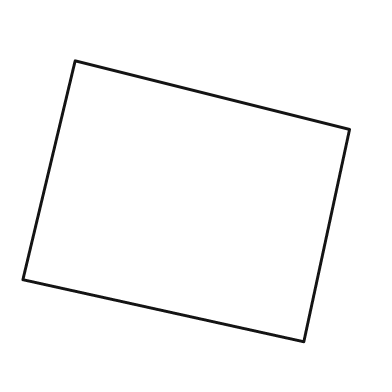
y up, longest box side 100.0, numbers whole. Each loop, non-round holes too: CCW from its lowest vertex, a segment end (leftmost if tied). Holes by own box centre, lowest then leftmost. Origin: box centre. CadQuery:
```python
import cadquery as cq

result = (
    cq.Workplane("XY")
    .moveTo(36.0, -43.0)
    .lineTo(50.0, 22.0)
    .lineTo(-34.0, 43.0)
    .lineTo(-50.0, -24.0)
    .close()
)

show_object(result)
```